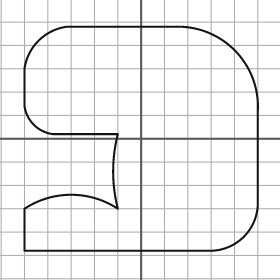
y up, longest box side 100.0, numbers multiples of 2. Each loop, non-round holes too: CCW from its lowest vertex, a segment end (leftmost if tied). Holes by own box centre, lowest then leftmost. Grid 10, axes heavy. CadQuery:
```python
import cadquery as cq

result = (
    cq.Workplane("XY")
    .moveTo(-50.0, -48.0)
    .lineTo(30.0, -48.0)
    .threePointArc((44.0, -42.0), (50.0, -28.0))
    .lineTo(50.0, 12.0)
    .threePointArc((40.0, 38.0), (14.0, 48.0))
    .lineTo(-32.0, 48.0)
    .threePointArc((-44.0, 42.0), (-50.0, 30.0))
    .lineTo(-50.0, 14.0)
    .threePointArc((-46.0, 6.0), (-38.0, 2.0))
    .lineTo(-10.0, 2.0)
    .threePointArc((-12.0, -14.0), (-10.0, -30.0))
    .threePointArc((-30.0, -24.0), (-50.0, -30.0))
    .close()
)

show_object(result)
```